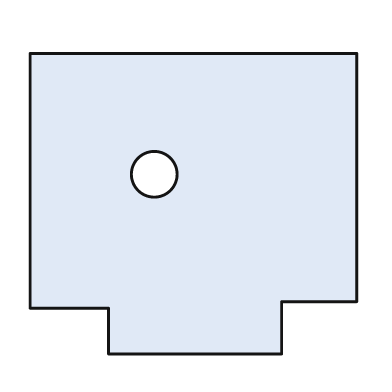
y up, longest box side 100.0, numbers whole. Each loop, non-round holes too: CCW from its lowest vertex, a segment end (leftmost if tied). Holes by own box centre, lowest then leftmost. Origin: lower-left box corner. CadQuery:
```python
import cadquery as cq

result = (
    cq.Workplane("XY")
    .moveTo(24.0, 0.0)
    .lineTo(77.0, 0.0)
    .lineTo(77.0, 16.0)
    .lineTo(100.0, 16.0)
    .lineTo(100.0, 92.0)
    .lineTo(0.0, 92.0)
    .lineTo(0.0, 14.0)
    .lineTo(24.0, 14.0)
    .close()
    .moveTo(38.0, 55.0)
    .circle(7.0)
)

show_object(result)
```